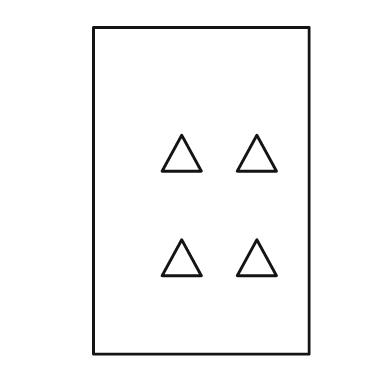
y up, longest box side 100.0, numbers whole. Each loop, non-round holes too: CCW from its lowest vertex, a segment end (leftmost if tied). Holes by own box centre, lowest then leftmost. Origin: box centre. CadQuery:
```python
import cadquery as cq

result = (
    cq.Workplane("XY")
    .moveTo(-33.0, -50.0)
    .lineTo(33.0, -50.0)
    .lineTo(33.0, 50.0)
    .lineTo(-33.0, 50.0)
    .close()
    .moveTo(-12.0, -26.0)
    .lineTo(0.0, -26.0)
    .lineTo(-6.0, -15.0)
    .close()
    .moveTo(11.0, -26.0)
    .lineTo(23.0, -26.0)
    .lineTo(17.0, -15.0)
    .close()
    .moveTo(-12.0, 6.0)
    .lineTo(0.0, 6.0)
    .lineTo(-6.0, 17.0)
    .close()
    .moveTo(11.0, 6.0)
    .lineTo(23.0, 6.0)
    .lineTo(17.0, 17.0)
    .close()
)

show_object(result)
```